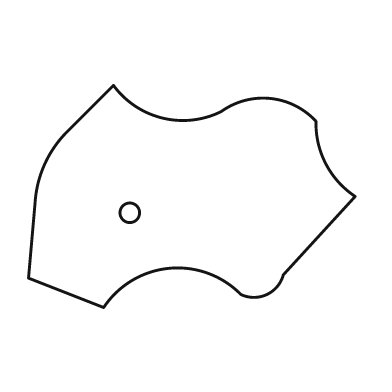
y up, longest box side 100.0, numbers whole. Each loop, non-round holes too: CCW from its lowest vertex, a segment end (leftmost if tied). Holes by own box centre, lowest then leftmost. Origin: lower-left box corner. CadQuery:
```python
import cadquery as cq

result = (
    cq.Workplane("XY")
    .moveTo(23.0, 0.0)
    .threePointArc((43.0, 12.0), (65.0, 4.0))
    .threePointArc((73.0, 4.0), (78.0, 10.0))
    .lineTo(100.0, 34.0)
    .threePointArc((91.0, 44.0), (88.0, 57.0))
    .threePointArc((74.0, 64.0), (59.0, 60.0))
    .threePointArc((41.0, 58.0), (26.0, 68.0))
    .lineTo(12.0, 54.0)
    .threePointArc((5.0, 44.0), (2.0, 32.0))
    .lineTo(0.0, 9.0)
    .close()
    .moveTo(31.0, 29.0)
    .circle(3.0)
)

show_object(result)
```